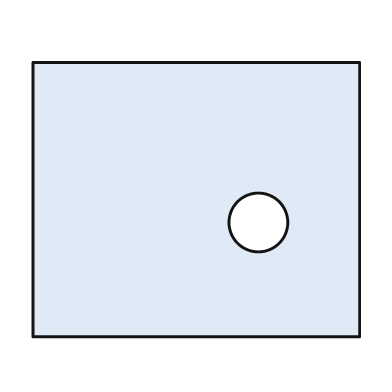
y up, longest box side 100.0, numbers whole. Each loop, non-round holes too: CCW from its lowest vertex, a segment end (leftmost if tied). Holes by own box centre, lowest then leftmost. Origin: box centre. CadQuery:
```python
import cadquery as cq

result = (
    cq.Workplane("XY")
    .moveTo(-50.0, -42.0)
    .lineTo(50.0, -42.0)
    .lineTo(50.0, 42.0)
    .lineTo(-50.0, 42.0)
    .close()
    .moveTo(19.0, -7.0)
    .circle(9.0)
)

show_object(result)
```